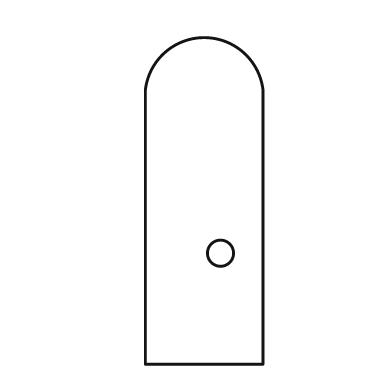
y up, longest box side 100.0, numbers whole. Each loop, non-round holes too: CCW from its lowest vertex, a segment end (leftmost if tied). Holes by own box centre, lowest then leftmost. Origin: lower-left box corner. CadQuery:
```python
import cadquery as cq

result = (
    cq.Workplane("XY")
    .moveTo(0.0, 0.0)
    .lineTo(36.0, 0.0)
    .lineTo(36.0, 84.0)
    .threePointArc((18.0, 100.0), (0.0, 84.0))
    .close()
    .moveTo(23.0, 34.0)
    .circle(4.0)
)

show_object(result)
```